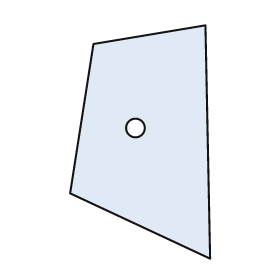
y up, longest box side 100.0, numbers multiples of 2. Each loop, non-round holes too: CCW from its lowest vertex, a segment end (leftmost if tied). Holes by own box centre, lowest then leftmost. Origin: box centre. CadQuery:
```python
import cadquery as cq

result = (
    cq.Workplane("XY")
    .moveTo(30.0, -50.0)
    .lineTo(28.0, 50.0)
    .lineTo(-20.0, 42.0)
    .lineTo(-30.0, -22.0)
    .close()
    .moveTo(-2.0, 6.0)
    .circle(4.0)
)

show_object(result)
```